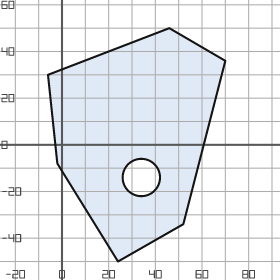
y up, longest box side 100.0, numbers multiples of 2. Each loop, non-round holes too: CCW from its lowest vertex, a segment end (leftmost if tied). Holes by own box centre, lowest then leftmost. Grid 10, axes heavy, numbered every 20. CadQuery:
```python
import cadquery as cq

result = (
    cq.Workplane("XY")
    .moveTo(24.0, -50.0)
    .lineTo(52.0, -34.0)
    .lineTo(70.0, 36.0)
    .lineTo(46.0, 50.0)
    .lineTo(-6.0, 30.0)
    .lineTo(-2.0, -8.0)
    .close()
    .moveTo(34.0, -14.0)
    .circle(8.0)
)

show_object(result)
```